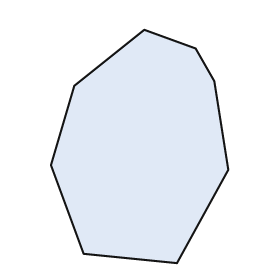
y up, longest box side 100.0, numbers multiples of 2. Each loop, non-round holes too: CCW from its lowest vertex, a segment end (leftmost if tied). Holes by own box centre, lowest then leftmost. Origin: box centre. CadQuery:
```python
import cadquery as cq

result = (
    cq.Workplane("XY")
    .moveTo(16.0, -50.0)
    .lineTo(38.0, -10.0)
    .lineTo(32.0, 28.0)
    .lineTo(24.0, 42.0)
    .lineTo(2.0, 50.0)
    .lineTo(-28.0, 26.0)
    .lineTo(-38.0, -8.0)
    .lineTo(-24.0, -46.0)
    .close()
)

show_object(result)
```